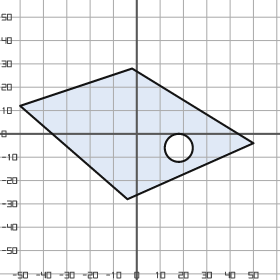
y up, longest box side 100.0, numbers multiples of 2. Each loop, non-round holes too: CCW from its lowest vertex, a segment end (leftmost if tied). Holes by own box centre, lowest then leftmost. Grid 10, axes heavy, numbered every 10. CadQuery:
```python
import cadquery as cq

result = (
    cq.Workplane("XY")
    .moveTo(-4.0, -28.0)
    .lineTo(50.0, -4.0)
    .lineTo(-2.0, 28.0)
    .lineTo(-50.0, 12.0)
    .close()
    .moveTo(18.0, -6.0)
    .circle(6.0)
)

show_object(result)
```